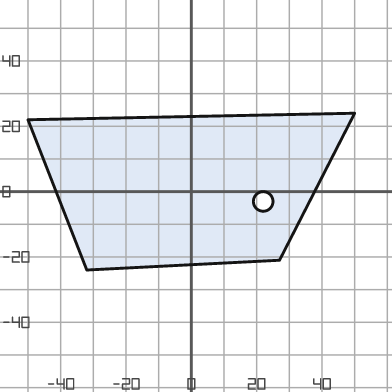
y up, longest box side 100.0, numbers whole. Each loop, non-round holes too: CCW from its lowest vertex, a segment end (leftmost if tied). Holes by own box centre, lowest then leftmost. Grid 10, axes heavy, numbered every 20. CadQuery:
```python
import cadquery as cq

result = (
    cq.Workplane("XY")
    .moveTo(-32.0, -24.0)
    .lineTo(27.0, -21.0)
    .lineTo(50.0, 24.0)
    .lineTo(-50.0, 22.0)
    .close()
    .moveTo(22.0, -3.0)
    .circle(3.0)
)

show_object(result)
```